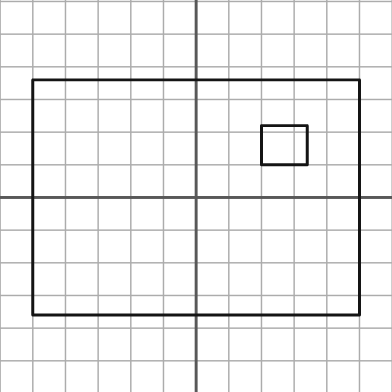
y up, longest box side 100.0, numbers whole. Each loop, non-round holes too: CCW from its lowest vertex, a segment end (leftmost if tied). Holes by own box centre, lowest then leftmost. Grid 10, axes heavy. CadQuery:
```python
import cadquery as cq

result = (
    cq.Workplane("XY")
    .moveTo(-50.0, -36.0)
    .lineTo(50.0, -36.0)
    .lineTo(50.0, 36.0)
    .lineTo(-50.0, 36.0)
    .close()
    .moveTo(20.0, 10.0)
    .lineTo(34.0, 10.0)
    .lineTo(34.0, 22.0)
    .lineTo(20.0, 22.0)
    .close()
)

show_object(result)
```